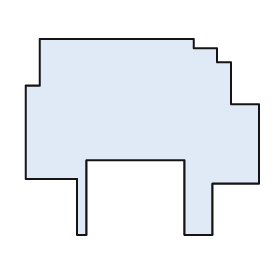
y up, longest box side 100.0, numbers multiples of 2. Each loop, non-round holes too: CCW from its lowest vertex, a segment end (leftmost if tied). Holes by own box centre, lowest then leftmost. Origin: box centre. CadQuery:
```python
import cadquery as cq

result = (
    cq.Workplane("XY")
    .moveTo(-28.0, -42.0)
    .lineTo(-24.0, -42.0)
    .lineTo(-24.0, -10.0)
    .lineTo(18.0, -10.0)
    .lineTo(18.0, -42.0)
    .lineTo(30.0, -42.0)
    .lineTo(30.0, -20.0)
    .lineTo(50.0, -20.0)
    .lineTo(50.0, 14.0)
    .lineTo(38.0, 14.0)
    .lineTo(38.0, 32.0)
    .lineTo(32.0, 32.0)
    .lineTo(32.0, 38.0)
    .lineTo(22.0, 38.0)
    .lineTo(22.0, 42.0)
    .lineTo(-44.0, 42.0)
    .lineTo(-44.0, 22.0)
    .lineTo(-50.0, 22.0)
    .lineTo(-50.0, -18.0)
    .lineTo(-28.0, -18.0)
    .close()
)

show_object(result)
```